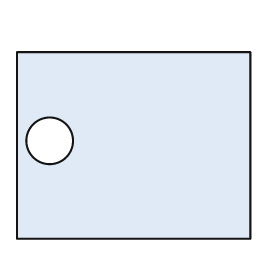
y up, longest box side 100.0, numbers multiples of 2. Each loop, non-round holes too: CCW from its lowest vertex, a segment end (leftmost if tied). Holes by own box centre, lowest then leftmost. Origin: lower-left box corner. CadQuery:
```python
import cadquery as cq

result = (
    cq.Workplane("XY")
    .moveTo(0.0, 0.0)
    .lineTo(100.0, 0.0)
    .lineTo(100.0, 80.0)
    .lineTo(0.0, 80.0)
    .close()
    .moveTo(14.0, 42.0)
    .circle(10.0)
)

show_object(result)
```